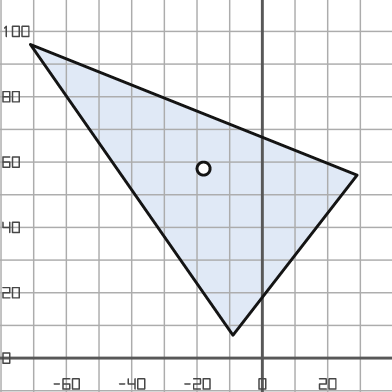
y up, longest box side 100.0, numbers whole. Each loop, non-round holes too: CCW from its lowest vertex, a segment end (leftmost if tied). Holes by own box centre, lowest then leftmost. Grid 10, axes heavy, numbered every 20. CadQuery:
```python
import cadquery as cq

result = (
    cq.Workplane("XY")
    .moveTo(-9.0, 7.0)
    .lineTo(29.0, 56.0)
    .lineTo(-71.0, 96.0)
    .close()
    .moveTo(-18.0, 58.0)
    .circle(2.0)
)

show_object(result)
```